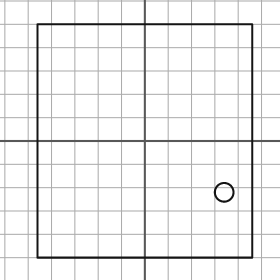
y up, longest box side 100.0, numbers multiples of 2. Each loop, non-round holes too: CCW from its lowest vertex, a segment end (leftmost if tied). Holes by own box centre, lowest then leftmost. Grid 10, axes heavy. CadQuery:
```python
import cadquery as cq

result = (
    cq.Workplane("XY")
    .moveTo(-46.0, -50.0)
    .lineTo(46.0, -50.0)
    .lineTo(46.0, 50.0)
    .lineTo(-46.0, 50.0)
    .close()
    .moveTo(34.0, -22.0)
    .circle(4.0)
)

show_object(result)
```